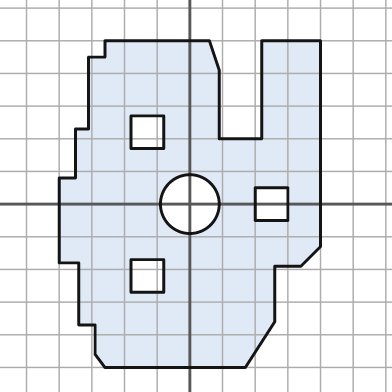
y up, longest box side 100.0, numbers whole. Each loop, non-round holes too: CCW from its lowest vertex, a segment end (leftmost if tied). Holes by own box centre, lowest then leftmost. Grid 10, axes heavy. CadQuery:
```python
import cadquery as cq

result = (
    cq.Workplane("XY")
    .moveTo(-26.0, -50.0)
    .lineTo(17.0, -50.0)
    .lineTo(26.0, -36.0)
    .lineTo(26.0, -19.0)
    .lineTo(34.0, -19.0)
    .lineTo(40.0, -13.0)
    .lineTo(40.0, 50.0)
    .lineTo(22.0, 50.0)
    .lineTo(22.0, 20.0)
    .lineTo(9.0, 20.0)
    .lineTo(9.0, 41.0)
    .lineTo(6.0, 50.0)
    .lineTo(-26.0, 50.0)
    .lineTo(-26.0, 45.0)
    .lineTo(-31.0, 45.0)
    .lineTo(-31.0, 23.0)
    .lineTo(-35.0, 23.0)
    .lineTo(-35.0, 8.0)
    .lineTo(-40.0, 8.0)
    .lineTo(-40.0, -18.0)
    .lineTo(-34.0, -18.0)
    .lineTo(-34.0, -37.0)
    .lineTo(-29.0, -37.0)
    .lineTo(-29.0, -46.0)
    .close()
    .moveTo(-18.0, -27.0)
    .lineTo(-8.0, -27.0)
    .lineTo(-8.0, -17.0)
    .lineTo(-18.0, -17.0)
    .close()
    .moveTo(0.0, 0.0)
    .circle(9.0)
    .moveTo(20.0, -5.0)
    .lineTo(30.0, -5.0)
    .lineTo(30.0, 5.0)
    .lineTo(20.0, 5.0)
    .close()
    .moveTo(-18.0, 17.0)
    .lineTo(-8.0, 17.0)
    .lineTo(-8.0, 27.0)
    .lineTo(-18.0, 27.0)
    .close()
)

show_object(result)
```